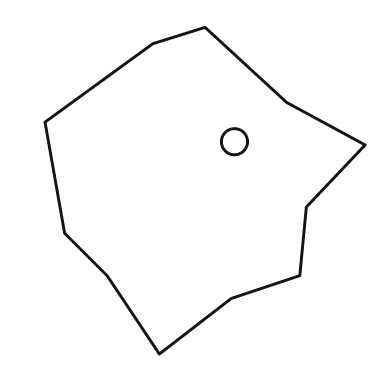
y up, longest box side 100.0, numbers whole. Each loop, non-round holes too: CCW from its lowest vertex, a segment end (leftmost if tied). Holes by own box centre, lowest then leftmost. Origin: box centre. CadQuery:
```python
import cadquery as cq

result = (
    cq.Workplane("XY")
    .moveTo(-14.0, -50.0)
    .lineTo(8.0, -33.0)
    .lineTo(29.0, -26.0)
    .lineTo(31.0, -5.0)
    .lineTo(49.0, 14.0)
    .lineTo(25.0, 27.0)
    .lineTo(0.0, 50.0)
    .lineTo(-16.0, 45.0)
    .lineTo(-49.0, 21.0)
    .lineTo(-43.0, -13.0)
    .lineTo(-30.0, -26.0)
    .close()
    .moveTo(9.0, 15.0)
    .circle(4.0)
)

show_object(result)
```